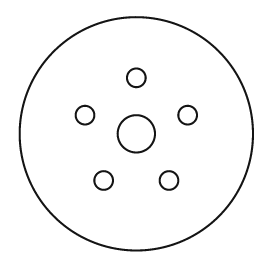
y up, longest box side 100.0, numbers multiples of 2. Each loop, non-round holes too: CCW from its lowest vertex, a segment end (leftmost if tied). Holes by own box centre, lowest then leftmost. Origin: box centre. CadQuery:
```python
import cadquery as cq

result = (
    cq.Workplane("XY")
    .moveTo(0.0, 0.0)
    .circle(50.0)
    .moveTo(-14.0, -20.0)
    .circle(4.0)
    .moveTo(14.0, -20.0)
    .circle(4.0)
    .moveTo(0.0, 0.0)
    .circle(8.0)
    .moveTo(-22.0, 8.0)
    .circle(4.0)
    .moveTo(22.0, 8.0)
    .circle(4.0)
    .moveTo(0.0, 24.0)
    .circle(4.0)
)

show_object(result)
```